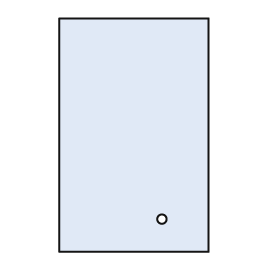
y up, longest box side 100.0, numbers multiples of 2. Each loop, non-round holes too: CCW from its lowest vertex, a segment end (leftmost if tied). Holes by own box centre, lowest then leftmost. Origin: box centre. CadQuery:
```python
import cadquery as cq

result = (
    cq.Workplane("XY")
    .moveTo(-32.0, -50.0)
    .lineTo(32.0, -50.0)
    .lineTo(32.0, 50.0)
    .lineTo(-32.0, 50.0)
    .close()
    .moveTo(12.0, -36.0)
    .circle(2.0)
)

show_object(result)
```